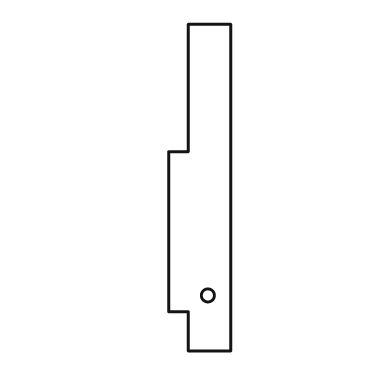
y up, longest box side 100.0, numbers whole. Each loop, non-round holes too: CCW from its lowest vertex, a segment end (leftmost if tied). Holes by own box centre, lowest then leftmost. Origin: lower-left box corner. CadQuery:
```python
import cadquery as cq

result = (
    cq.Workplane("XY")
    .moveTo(6.0, 0.0)
    .lineTo(19.0, 0.0)
    .lineTo(19.0, 100.0)
    .lineTo(6.0, 100.0)
    .lineTo(6.0, 61.0)
    .lineTo(0.0, 61.0)
    .lineTo(0.0, 12.0)
    .lineTo(6.0, 12.0)
    .close()
    .moveTo(12.0, 17.0)
    .circle(2.0)
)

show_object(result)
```